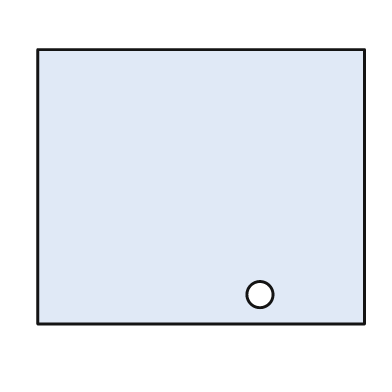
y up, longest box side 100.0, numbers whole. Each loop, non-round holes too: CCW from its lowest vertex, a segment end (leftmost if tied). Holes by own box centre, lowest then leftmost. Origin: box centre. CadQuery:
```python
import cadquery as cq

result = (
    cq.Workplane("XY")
    .moveTo(-50.0, -42.0)
    .lineTo(50.0, -42.0)
    .lineTo(50.0, 42.0)
    .lineTo(-50.0, 42.0)
    .close()
    .moveTo(18.0, -33.0)
    .circle(4.0)
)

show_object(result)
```